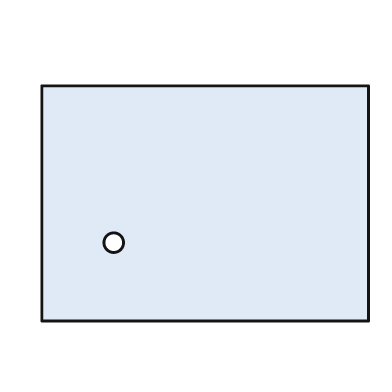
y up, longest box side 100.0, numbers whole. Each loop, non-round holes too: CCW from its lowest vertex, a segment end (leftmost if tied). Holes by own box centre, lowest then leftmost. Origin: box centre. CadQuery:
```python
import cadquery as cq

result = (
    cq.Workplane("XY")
    .moveTo(-50.0, -36.0)
    .lineTo(50.0, -36.0)
    .lineTo(50.0, 36.0)
    .lineTo(-50.0, 36.0)
    .close()
    .moveTo(-28.0, -12.0)
    .circle(3.0)
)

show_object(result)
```